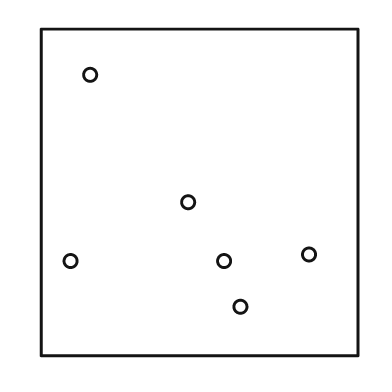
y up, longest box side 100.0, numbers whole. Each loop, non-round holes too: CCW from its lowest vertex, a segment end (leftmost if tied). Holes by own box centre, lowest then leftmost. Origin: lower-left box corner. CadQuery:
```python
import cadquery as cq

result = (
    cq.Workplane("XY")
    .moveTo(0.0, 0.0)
    .lineTo(97.0, 0.0)
    .lineTo(97.0, 100.0)
    .lineTo(0.0, 100.0)
    .close()
    .moveTo(61.0, 15.0)
    .circle(2.0)
    .moveTo(9.0, 29.0)
    .circle(2.0)
    .moveTo(56.0, 29.0)
    .circle(2.0)
    .moveTo(82.0, 31.0)
    .circle(2.0)
    .moveTo(45.0, 47.0)
    .circle(2.0)
    .moveTo(15.0, 86.0)
    .circle(2.0)
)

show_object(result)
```